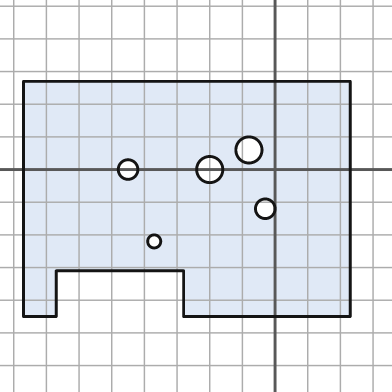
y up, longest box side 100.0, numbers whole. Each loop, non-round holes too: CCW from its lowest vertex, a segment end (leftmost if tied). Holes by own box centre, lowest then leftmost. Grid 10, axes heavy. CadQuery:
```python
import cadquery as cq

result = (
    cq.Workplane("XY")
    .moveTo(-77.0, -45.0)
    .lineTo(-67.0, -45.0)
    .lineTo(-67.0, -31.0)
    .lineTo(-28.0, -31.0)
    .lineTo(-28.0, -45.0)
    .lineTo(23.0, -45.0)
    .lineTo(23.0, 27.0)
    .lineTo(-77.0, 27.0)
    .close()
    .moveTo(-37.0, -22.0)
    .circle(2.0)
    .moveTo(-3.0, -12.0)
    .circle(3.0)
    .moveTo(-45.0, 0.0)
    .circle(3.0)
    .moveTo(-20.0, 0.0)
    .circle(4.0)
    .moveTo(-8.0, 6.0)
    .circle(4.0)
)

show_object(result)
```